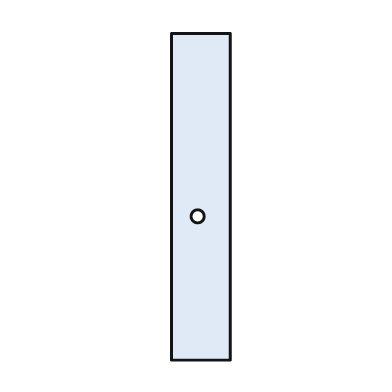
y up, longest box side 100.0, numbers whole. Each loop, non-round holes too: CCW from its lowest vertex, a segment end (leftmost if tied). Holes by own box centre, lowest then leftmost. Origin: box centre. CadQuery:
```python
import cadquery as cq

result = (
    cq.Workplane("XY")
    .moveTo(-9.0, -50.0)
    .lineTo(9.0, -50.0)
    .lineTo(9.0, 50.0)
    .lineTo(-9.0, 50.0)
    .close()
    .moveTo(-1.0, -6.0)
    .circle(2.0)
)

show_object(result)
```